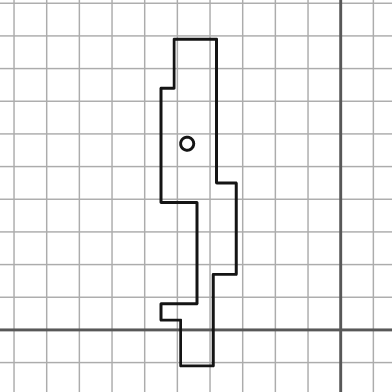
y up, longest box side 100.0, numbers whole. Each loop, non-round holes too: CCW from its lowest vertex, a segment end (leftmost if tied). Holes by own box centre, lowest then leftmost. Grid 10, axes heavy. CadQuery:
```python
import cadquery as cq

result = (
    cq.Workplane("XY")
    .moveTo(-49.0, -11.0)
    .lineTo(-39.0, -11.0)
    .lineTo(-39.0, 17.0)
    .lineTo(-32.0, 17.0)
    .lineTo(-32.0, 45.0)
    .lineTo(-38.0, 45.0)
    .lineTo(-38.0, 89.0)
    .lineTo(-51.0, 89.0)
    .lineTo(-51.0, 74.0)
    .lineTo(-55.0, 74.0)
    .lineTo(-55.0, 39.0)
    .lineTo(-44.0, 39.0)
    .lineTo(-44.0, 8.0)
    .lineTo(-55.0, 8.0)
    .lineTo(-55.0, 3.0)
    .lineTo(-49.0, 3.0)
    .close()
    .moveTo(-47.0, 57.0)
    .circle(2.0)
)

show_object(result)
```